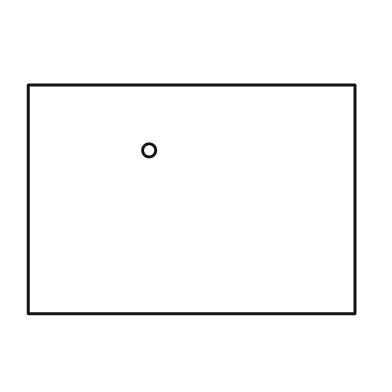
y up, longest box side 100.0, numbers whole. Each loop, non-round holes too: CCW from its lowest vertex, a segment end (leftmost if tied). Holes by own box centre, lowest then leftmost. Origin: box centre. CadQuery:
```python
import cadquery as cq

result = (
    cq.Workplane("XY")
    .moveTo(-50.0, -35.0)
    .lineTo(50.0, -35.0)
    .lineTo(50.0, 35.0)
    .lineTo(-50.0, 35.0)
    .close()
    .moveTo(-13.0, 15.0)
    .circle(2.0)
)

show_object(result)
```